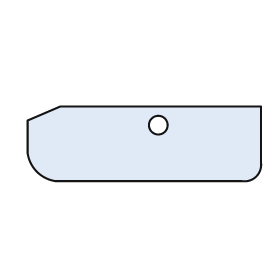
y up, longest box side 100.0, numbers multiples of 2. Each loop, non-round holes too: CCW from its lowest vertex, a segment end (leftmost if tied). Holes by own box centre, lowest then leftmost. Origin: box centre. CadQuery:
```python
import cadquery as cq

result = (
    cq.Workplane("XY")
    .moveTo(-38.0, -16.0)
    .lineTo(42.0, -16.0)
    .threePointArc((48.0, -14.0), (50.0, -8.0))
    .lineTo(50.0, 16.0)
    .lineTo(-36.0, 16.0)
    .lineTo(-50.0, 10.0)
    .lineTo(-50.0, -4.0)
    .threePointArc((-46.0, -12.0), (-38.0, -16.0))
    .close()
    .moveTo(6.0, 8.0)
    .circle(4.0)
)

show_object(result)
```